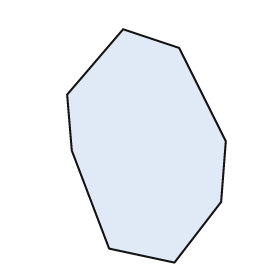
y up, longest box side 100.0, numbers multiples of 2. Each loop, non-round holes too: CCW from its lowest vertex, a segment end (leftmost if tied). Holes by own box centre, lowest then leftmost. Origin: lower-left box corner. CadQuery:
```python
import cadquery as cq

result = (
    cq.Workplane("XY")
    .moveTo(46.0, 0.0)
    .lineTo(66.0, 26.0)
    .lineTo(68.0, 52.0)
    .lineTo(48.0, 92.0)
    .lineTo(24.0, 100.0)
    .lineTo(0.0, 72.0)
    .lineTo(2.0, 48.0)
    .lineTo(18.0, 6.0)
    .close()
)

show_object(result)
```